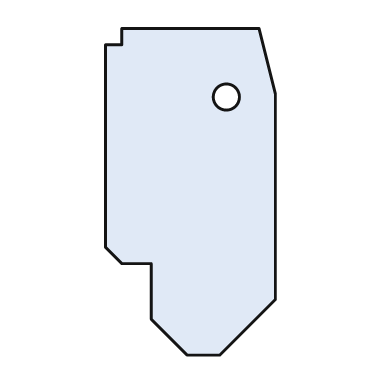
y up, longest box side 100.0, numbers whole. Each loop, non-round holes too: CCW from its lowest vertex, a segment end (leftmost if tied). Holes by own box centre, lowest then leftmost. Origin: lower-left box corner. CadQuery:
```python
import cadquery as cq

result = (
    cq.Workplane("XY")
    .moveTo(25.0, 0.0)
    .lineTo(35.0, 0.0)
    .lineTo(52.0, 17.0)
    .lineTo(52.0, 80.0)
    .lineTo(47.0, 100.0)
    .lineTo(5.0, 100.0)
    .lineTo(5.0, 95.0)
    .lineTo(0.0, 95.0)
    .lineTo(0.0, 33.0)
    .lineTo(5.0, 28.0)
    .lineTo(14.0, 28.0)
    .lineTo(14.0, 11.0)
    .close()
    .moveTo(37.0, 79.0)
    .circle(4.0)
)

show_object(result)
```